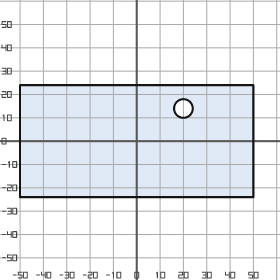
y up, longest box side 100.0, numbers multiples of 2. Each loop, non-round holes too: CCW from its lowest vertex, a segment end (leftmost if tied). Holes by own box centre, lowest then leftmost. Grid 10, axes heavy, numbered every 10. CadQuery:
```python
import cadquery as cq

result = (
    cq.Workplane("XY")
    .moveTo(-50.0, -24.0)
    .lineTo(50.0, -24.0)
    .lineTo(50.0, 24.0)
    .lineTo(-50.0, 24.0)
    .close()
    .moveTo(20.0, 14.0)
    .circle(4.0)
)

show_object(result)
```